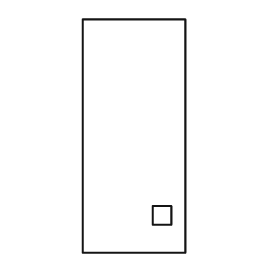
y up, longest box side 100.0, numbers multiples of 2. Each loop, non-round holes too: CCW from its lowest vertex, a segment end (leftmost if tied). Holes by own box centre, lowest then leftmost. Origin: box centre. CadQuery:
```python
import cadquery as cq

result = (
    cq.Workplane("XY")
    .moveTo(-22.0, -50.0)
    .lineTo(22.0, -50.0)
    .lineTo(22.0, 50.0)
    .lineTo(-22.0, 50.0)
    .close()
    .moveTo(8.0, -38.0)
    .lineTo(16.0, -38.0)
    .lineTo(16.0, -30.0)
    .lineTo(8.0, -30.0)
    .close()
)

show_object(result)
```